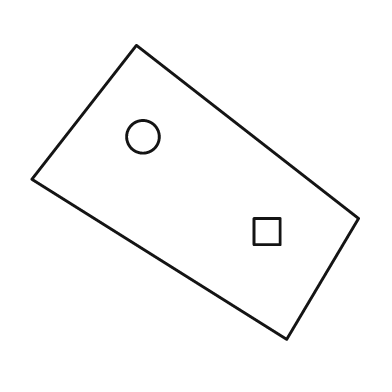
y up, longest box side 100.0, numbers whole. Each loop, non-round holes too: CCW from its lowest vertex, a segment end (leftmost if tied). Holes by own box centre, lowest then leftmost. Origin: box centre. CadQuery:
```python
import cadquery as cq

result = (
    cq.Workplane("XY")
    .moveTo(28.0, -45.0)
    .lineTo(50.0, -8.0)
    .lineTo(-18.0, 45.0)
    .lineTo(-50.0, 4.0)
    .close()
    .moveTo(18.0, -16.0)
    .lineTo(26.0, -16.0)
    .lineTo(26.0, -8.0)
    .lineTo(18.0, -8.0)
    .close()
    .moveTo(-16.0, 17.0)
    .circle(5.0)
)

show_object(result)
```